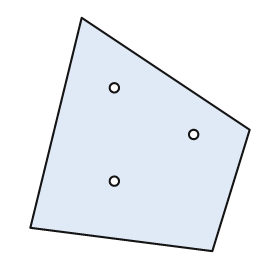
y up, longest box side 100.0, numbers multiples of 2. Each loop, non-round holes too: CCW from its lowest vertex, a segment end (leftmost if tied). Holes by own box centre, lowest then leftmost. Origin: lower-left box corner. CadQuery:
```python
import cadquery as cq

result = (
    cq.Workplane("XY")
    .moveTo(78.0, 0.0)
    .lineTo(94.0, 52.0)
    .lineTo(22.0, 100.0)
    .lineTo(0.0, 10.0)
    .close()
    .moveTo(36.0, 30.0)
    .circle(2.0)
    .moveTo(70.0, 50.0)
    .circle(2.0)
    .moveTo(36.0, 70.0)
    .circle(2.0)
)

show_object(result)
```